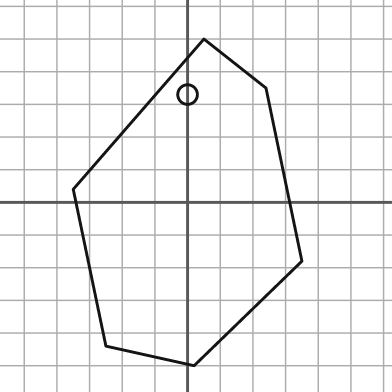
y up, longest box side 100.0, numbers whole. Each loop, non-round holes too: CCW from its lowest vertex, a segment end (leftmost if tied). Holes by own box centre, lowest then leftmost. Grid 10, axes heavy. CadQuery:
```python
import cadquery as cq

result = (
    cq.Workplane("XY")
    .moveTo(2.0, -50.0)
    .lineTo(35.0, -18.0)
    .lineTo(24.0, 35.0)
    .lineTo(5.0, 50.0)
    .lineTo(-35.0, 4.0)
    .lineTo(-25.0, -44.0)
    .close()
    .moveTo(0.0, 33.0)
    .circle(3.0)
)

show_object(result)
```